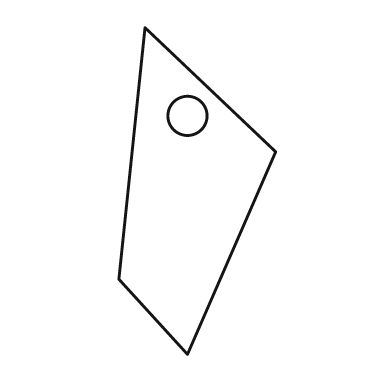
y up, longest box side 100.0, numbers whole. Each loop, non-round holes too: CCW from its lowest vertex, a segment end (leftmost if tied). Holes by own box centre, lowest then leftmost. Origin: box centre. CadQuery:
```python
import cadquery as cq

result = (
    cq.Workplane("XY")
    .moveTo(-3.0, -50.0)
    .lineTo(24.0, 12.0)
    .lineTo(-16.0, 50.0)
    .lineTo(-24.0, -27.0)
    .close()
    .moveTo(-3.0, 23.0)
    .circle(6.0)
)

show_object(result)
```